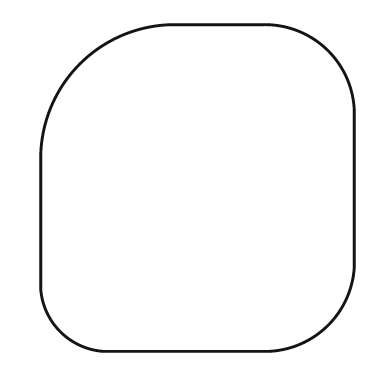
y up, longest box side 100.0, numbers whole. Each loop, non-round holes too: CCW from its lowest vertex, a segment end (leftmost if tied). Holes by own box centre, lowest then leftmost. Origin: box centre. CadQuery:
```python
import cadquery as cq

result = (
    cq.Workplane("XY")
    .moveTo(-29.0, -50.0)
    .lineTo(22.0, -50.0)
    .threePointArc((40.0, -42.0), (48.0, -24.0))
    .lineTo(48.0, 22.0)
    .threePointArc((40.0, 42.0), (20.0, 50.0))
    .lineTo(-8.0, 50.0)
    .threePointArc((-36.0, 38.0), (-48.0, 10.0))
    .lineTo(-48.0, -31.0)
    .threePointArc((-42.0, -44.0), (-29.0, -50.0))
    .close()
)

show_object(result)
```